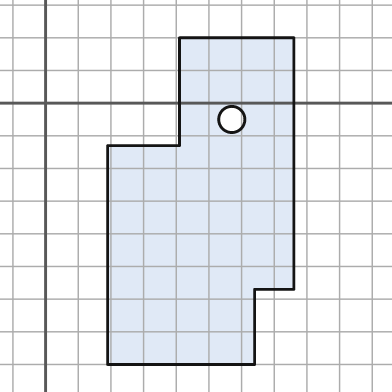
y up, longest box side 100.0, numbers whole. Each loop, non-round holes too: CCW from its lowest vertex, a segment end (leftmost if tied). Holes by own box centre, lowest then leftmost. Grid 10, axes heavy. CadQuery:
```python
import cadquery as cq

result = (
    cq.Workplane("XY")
    .moveTo(19.0, -80.0)
    .lineTo(64.0, -80.0)
    .lineTo(64.0, -57.0)
    .lineTo(76.0, -57.0)
    .lineTo(76.0, 20.0)
    .lineTo(41.0, 20.0)
    .lineTo(41.0, -13.0)
    .lineTo(19.0, -13.0)
    .close()
    .moveTo(57.0, -5.0)
    .circle(4.0)
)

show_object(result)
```